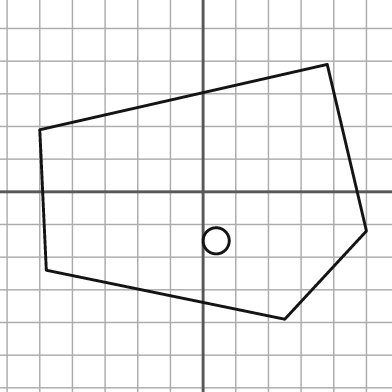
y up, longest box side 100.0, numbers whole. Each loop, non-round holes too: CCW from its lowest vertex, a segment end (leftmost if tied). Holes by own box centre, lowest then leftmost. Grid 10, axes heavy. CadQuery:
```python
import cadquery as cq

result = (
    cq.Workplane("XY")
    .moveTo(25.0, -39.0)
    .lineTo(50.0, -12.0)
    .lineTo(38.0, 39.0)
    .lineTo(-50.0, 19.0)
    .lineTo(-48.0, -24.0)
    .close()
    .moveTo(4.0, -15.0)
    .circle(4.0)
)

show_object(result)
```